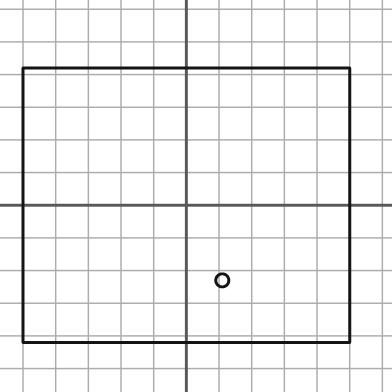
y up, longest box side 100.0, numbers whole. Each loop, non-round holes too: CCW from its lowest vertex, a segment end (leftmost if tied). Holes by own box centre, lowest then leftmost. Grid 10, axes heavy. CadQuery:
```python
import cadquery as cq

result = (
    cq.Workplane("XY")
    .moveTo(-50.0, -42.0)
    .lineTo(50.0, -42.0)
    .lineTo(50.0, 42.0)
    .lineTo(-50.0, 42.0)
    .close()
    .moveTo(11.0, -23.0)
    .circle(2.0)
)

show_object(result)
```